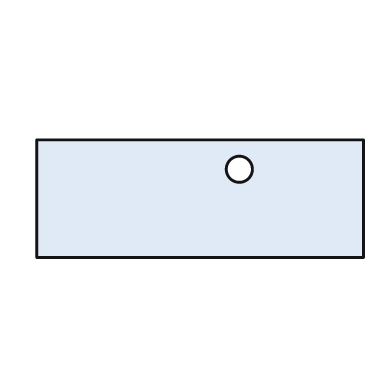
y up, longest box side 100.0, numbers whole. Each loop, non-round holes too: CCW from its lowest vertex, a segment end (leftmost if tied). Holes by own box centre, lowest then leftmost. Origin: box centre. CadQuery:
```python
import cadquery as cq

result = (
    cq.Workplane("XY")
    .moveTo(-50.0, -18.0)
    .lineTo(50.0, -18.0)
    .lineTo(50.0, 18.0)
    .lineTo(-50.0, 18.0)
    .close()
    .moveTo(12.0, 9.0)
    .circle(4.0)
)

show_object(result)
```